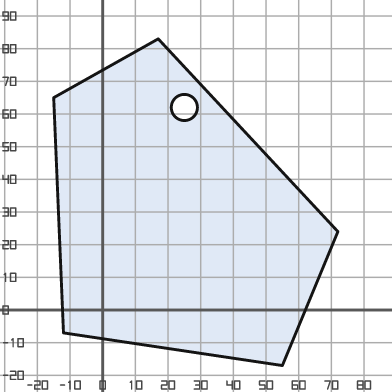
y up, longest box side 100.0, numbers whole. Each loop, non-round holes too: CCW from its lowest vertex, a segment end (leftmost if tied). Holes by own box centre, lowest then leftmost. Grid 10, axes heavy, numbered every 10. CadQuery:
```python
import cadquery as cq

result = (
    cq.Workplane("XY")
    .moveTo(55.0, -17.0)
    .lineTo(72.0, 24.0)
    .lineTo(17.0, 83.0)
    .lineTo(-15.0, 65.0)
    .lineTo(-12.0, -7.0)
    .close()
    .moveTo(25.0, 62.0)
    .circle(4.0)
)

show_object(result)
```